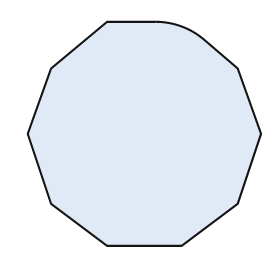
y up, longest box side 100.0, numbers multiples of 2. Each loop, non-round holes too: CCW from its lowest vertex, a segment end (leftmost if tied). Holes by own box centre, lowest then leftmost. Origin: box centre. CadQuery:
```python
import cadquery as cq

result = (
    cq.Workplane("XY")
    .moveTo(-16.0, -48.0)
    .lineTo(16.0, -48.0)
    .lineTo(40.0, -30.0)
    .lineTo(50.0, 0.0)
    .lineTo(40.0, 28.0)
    .lineTo(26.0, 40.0)
    .threePointArc((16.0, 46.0), (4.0, 48.0))
    .lineTo(-16.0, 48.0)
    .lineTo(-40.0, 28.0)
    .lineTo(-50.0, 0.0)
    .lineTo(-40.0, -30.0)
    .close()
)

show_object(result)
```